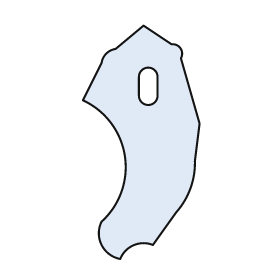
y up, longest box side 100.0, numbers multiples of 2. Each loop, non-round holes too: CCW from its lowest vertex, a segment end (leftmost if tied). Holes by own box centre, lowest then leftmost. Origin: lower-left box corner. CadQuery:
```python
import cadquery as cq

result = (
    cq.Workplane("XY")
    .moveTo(16.0, 0.0)
    .threePointArc((22.0, 6.0), (30.0, 6.0))
    .lineTo(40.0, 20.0)
    .threePointArc((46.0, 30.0), (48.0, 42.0))
    .lineTo(50.0, 58.0)
    .lineTo(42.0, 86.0)
    .threePointArc((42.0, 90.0), (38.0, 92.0))
    .lineTo(26.0, 100.0)
    .lineTo(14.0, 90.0)
    .threePointArc((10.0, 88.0), (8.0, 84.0))
    .lineTo(0.0, 68.0)
    .threePointArc((18.0, 44.0), (8.0, 16.0))
    .threePointArc((8.0, 6.0), (16.0, 0.0))
    .close()
    .moveTo(24.0, 70.0)
    .threePointArc((28.0, 66.0), (32.0, 70.0))
    .lineTo(32.0, 78.0)
    .threePointArc((28.0, 82.0), (24.0, 78.0))
    .close()
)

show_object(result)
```